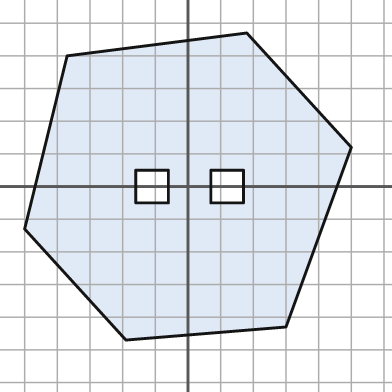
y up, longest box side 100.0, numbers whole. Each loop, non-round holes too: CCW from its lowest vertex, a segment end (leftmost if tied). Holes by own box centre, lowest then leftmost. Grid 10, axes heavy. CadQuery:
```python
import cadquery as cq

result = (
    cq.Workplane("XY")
    .moveTo(-19.0, -47.0)
    .lineTo(30.0, -43.0)
    .lineTo(50.0, 12.0)
    .lineTo(18.0, 47.0)
    .lineTo(-37.0, 40.0)
    .lineTo(-50.0, -13.0)
    .close()
    .moveTo(-16.0, -5.0)
    .lineTo(-6.0, -5.0)
    .lineTo(-6.0, 5.0)
    .lineTo(-16.0, 5.0)
    .close()
    .moveTo(7.0, -5.0)
    .lineTo(17.0, -5.0)
    .lineTo(17.0, 5.0)
    .lineTo(7.0, 5.0)
    .close()
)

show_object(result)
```